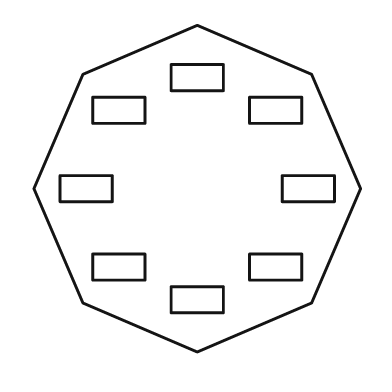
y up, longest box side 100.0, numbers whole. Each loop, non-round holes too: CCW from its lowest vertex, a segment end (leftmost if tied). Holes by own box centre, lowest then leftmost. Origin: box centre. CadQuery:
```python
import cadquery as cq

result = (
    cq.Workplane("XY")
    .moveTo(0.0, -50.0)
    .lineTo(35.0, -35.0)
    .lineTo(50.0, 0.0)
    .lineTo(35.0, 35.0)
    .lineTo(0.0, 50.0)
    .lineTo(-35.0, 35.0)
    .lineTo(-50.0, 0.0)
    .lineTo(-35.0, -35.0)
    .close()
    .moveTo(-8.0, -38.0)
    .lineTo(8.0, -38.0)
    .lineTo(8.0, -30.0)
    .lineTo(-8.0, -30.0)
    .close()
    .moveTo(-32.0, -28.0)
    .lineTo(-16.0, -28.0)
    .lineTo(-16.0, -20.0)
    .lineTo(-32.0, -20.0)
    .close()
    .moveTo(16.0, -28.0)
    .lineTo(32.0, -28.0)
    .lineTo(32.0, -20.0)
    .lineTo(16.0, -20.0)
    .close()
    .moveTo(-42.0, -4.0)
    .lineTo(-26.0, -4.0)
    .lineTo(-26.0, 4.0)
    .lineTo(-42.0, 4.0)
    .close()
    .moveTo(26.0, -4.0)
    .lineTo(42.0, -4.0)
    .lineTo(42.0, 4.0)
    .lineTo(26.0, 4.0)
    .close()
    .moveTo(-32.0, 20.0)
    .lineTo(-16.0, 20.0)
    .lineTo(-16.0, 28.0)
    .lineTo(-32.0, 28.0)
    .close()
    .moveTo(16.0, 20.0)
    .lineTo(32.0, 20.0)
    .lineTo(32.0, 28.0)
    .lineTo(16.0, 28.0)
    .close()
    .moveTo(-8.0, 30.0)
    .lineTo(8.0, 30.0)
    .lineTo(8.0, 38.0)
    .lineTo(-8.0, 38.0)
    .close()
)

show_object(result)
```